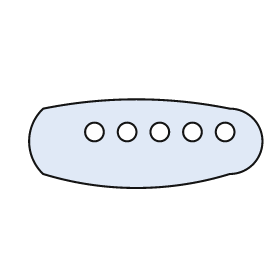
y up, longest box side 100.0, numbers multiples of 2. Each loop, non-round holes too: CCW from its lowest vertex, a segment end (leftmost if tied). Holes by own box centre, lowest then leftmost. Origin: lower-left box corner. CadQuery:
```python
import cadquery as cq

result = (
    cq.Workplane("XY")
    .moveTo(6.0, 6.0)
    .threePointArc((46.0, 0.0), (86.0, 6.0))
    .threePointArc((100.0, 20.0), (86.0, 34.0))
    .threePointArc((46.0, 38.0), (6.0, 34.0))
    .threePointArc((0.0, 20.0), (6.0, 6.0))
    .close()
    .moveTo(28.0, 24.0)
    .circle(4.0)
    .moveTo(42.0, 24.0)
    .circle(4.0)
    .moveTo(56.0, 24.0)
    .circle(4.0)
    .moveTo(70.0, 24.0)
    .circle(4.0)
    .moveTo(84.0, 24.0)
    .circle(4.0)
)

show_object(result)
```